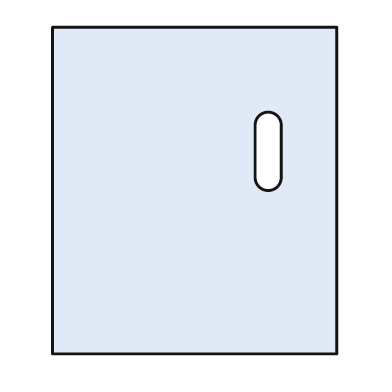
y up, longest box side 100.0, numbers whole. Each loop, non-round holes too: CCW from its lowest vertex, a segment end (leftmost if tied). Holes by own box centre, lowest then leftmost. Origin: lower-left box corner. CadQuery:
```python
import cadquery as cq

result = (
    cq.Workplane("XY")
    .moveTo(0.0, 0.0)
    .lineTo(87.0, 0.0)
    .lineTo(87.0, 100.0)
    .lineTo(0.0, 100.0)
    .close()
    .moveTo(62.0, 54.0)
    .threePointArc((66.0, 50.0), (70.0, 54.0))
    .lineTo(70.0, 70.0)
    .threePointArc((66.0, 74.0), (62.0, 70.0))
    .close()
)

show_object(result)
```